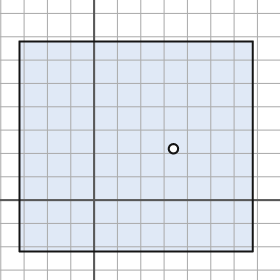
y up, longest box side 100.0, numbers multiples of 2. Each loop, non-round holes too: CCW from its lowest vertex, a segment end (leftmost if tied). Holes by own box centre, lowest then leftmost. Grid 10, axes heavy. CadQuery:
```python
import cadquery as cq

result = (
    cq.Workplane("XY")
    .moveTo(-32.0, -22.0)
    .lineTo(68.0, -22.0)
    .lineTo(68.0, 68.0)
    .lineTo(-32.0, 68.0)
    .close()
    .moveTo(34.0, 22.0)
    .circle(2.0)
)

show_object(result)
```